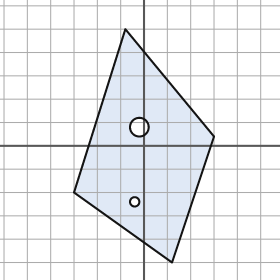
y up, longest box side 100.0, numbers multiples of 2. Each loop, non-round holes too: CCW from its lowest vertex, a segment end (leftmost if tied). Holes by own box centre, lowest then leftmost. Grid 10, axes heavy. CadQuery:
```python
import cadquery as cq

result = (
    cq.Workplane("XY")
    .moveTo(12.0, -50.0)
    .lineTo(30.0, 4.0)
    .lineTo(-8.0, 50.0)
    .lineTo(-30.0, -20.0)
    .close()
    .moveTo(-4.0, -24.0)
    .circle(2.0)
    .moveTo(-2.0, 8.0)
    .circle(4.0)
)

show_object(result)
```